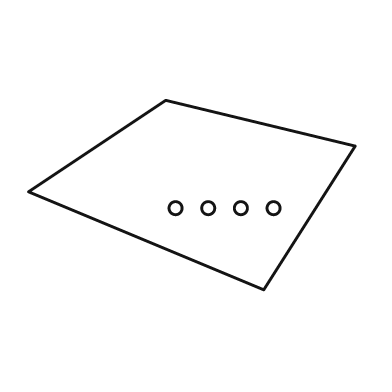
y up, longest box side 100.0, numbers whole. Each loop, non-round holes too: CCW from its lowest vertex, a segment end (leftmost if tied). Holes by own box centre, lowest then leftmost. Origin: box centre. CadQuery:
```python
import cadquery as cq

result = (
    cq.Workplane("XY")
    .moveTo(22.0, -29.0)
    .lineTo(50.0, 15.0)
    .lineTo(-8.0, 29.0)
    .lineTo(-50.0, 1.0)
    .close()
    .moveTo(-5.0, -4.0)
    .circle(2.0)
    .moveTo(5.0, -4.0)
    .circle(2.0)
    .moveTo(15.0, -4.0)
    .circle(2.0)
    .moveTo(25.0, -4.0)
    .circle(2.0)
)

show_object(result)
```